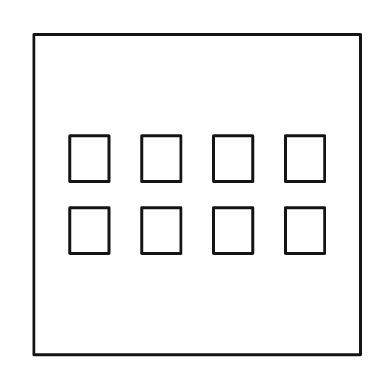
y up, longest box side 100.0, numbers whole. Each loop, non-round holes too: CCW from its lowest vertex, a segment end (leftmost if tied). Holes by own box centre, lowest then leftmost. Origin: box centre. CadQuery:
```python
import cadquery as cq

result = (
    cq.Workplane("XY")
    .moveTo(-50.0, -49.0)
    .lineTo(50.0, -49.0)
    .lineTo(50.0, 49.0)
    .lineTo(-50.0, 49.0)
    .close()
    .moveTo(-39.0, -18.0)
    .lineTo(-27.0, -18.0)
    .lineTo(-27.0, -4.0)
    .lineTo(-39.0, -4.0)
    .close()
    .moveTo(-17.0, -18.0)
    .lineTo(-5.0, -18.0)
    .lineTo(-5.0, -4.0)
    .lineTo(-17.0, -4.0)
    .close()
    .moveTo(5.0, -18.0)
    .lineTo(17.0, -18.0)
    .lineTo(17.0, -4.0)
    .lineTo(5.0, -4.0)
    .close()
    .moveTo(27.0, -18.0)
    .lineTo(39.0, -18.0)
    .lineTo(39.0, -4.0)
    .lineTo(27.0, -4.0)
    .close()
    .moveTo(-39.0, 4.0)
    .lineTo(-27.0, 4.0)
    .lineTo(-27.0, 18.0)
    .lineTo(-39.0, 18.0)
    .close()
    .moveTo(-17.0, 4.0)
    .lineTo(-5.0, 4.0)
    .lineTo(-5.0, 18.0)
    .lineTo(-17.0, 18.0)
    .close()
    .moveTo(5.0, 4.0)
    .lineTo(17.0, 4.0)
    .lineTo(17.0, 18.0)
    .lineTo(5.0, 18.0)
    .close()
    .moveTo(27.0, 4.0)
    .lineTo(39.0, 4.0)
    .lineTo(39.0, 18.0)
    .lineTo(27.0, 18.0)
    .close()
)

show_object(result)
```